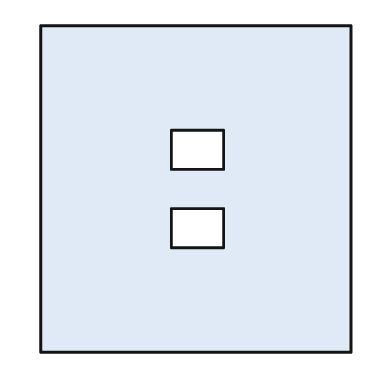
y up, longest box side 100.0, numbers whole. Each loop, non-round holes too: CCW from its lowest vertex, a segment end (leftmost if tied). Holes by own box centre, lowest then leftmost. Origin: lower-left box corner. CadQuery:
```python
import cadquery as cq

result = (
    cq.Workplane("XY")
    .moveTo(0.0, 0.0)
    .lineTo(95.0, 0.0)
    .lineTo(95.0, 100.0)
    .lineTo(0.0, 100.0)
    .close()
    .moveTo(40.0, 32.0)
    .lineTo(56.0, 32.0)
    .lineTo(56.0, 44.0)
    .lineTo(40.0, 44.0)
    .close()
    .moveTo(40.0, 56.0)
    .lineTo(56.0, 56.0)
    .lineTo(56.0, 68.0)
    .lineTo(40.0, 68.0)
    .close()
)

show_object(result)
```